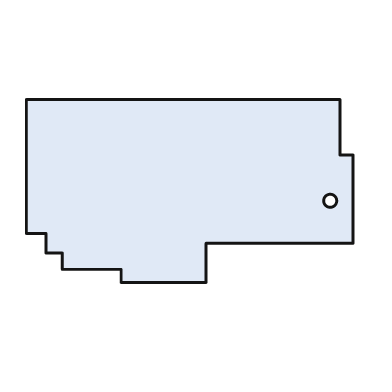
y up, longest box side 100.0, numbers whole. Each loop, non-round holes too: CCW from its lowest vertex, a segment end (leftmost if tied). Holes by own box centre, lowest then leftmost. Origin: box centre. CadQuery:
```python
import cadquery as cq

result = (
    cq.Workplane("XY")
    .moveTo(-21.0, -28.0)
    .lineTo(5.0, -28.0)
    .lineTo(5.0, -16.0)
    .lineTo(50.0, -16.0)
    .lineTo(50.0, 11.0)
    .lineTo(46.0, 11.0)
    .lineTo(46.0, 28.0)
    .lineTo(-50.0, 28.0)
    .lineTo(-50.0, -13.0)
    .lineTo(-44.0, -13.0)
    .lineTo(-44.0, -19.0)
    .lineTo(-39.0, -19.0)
    .lineTo(-39.0, -24.0)
    .lineTo(-21.0, -24.0)
    .close()
    .moveTo(43.0, -3.0)
    .circle(2.0)
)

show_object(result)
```